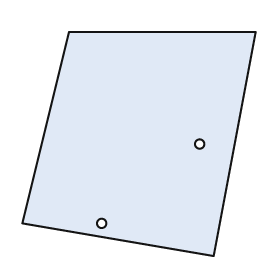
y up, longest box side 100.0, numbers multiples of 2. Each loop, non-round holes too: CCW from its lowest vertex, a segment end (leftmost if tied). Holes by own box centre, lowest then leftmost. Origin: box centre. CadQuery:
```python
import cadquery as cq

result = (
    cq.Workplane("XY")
    .moveTo(32.0, -48.0)
    .lineTo(50.0, 48.0)
    .lineTo(-30.0, 48.0)
    .lineTo(-50.0, -34.0)
    .close()
    .moveTo(-16.0, -34.0)
    .circle(2.0)
    .moveTo(26.0, 0.0)
    .circle(2.0)
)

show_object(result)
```